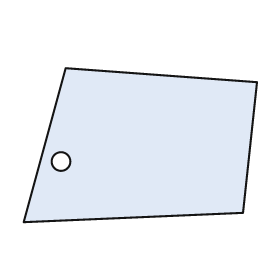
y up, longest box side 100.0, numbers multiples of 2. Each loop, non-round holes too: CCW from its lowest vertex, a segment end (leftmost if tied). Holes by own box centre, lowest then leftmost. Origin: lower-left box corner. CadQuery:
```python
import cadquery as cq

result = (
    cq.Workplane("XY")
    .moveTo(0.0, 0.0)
    .lineTo(94.0, 4.0)
    .lineTo(100.0, 60.0)
    .lineTo(18.0, 66.0)
    .close()
    .moveTo(16.0, 26.0)
    .circle(4.0)
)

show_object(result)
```